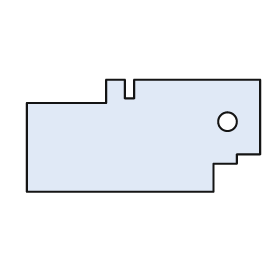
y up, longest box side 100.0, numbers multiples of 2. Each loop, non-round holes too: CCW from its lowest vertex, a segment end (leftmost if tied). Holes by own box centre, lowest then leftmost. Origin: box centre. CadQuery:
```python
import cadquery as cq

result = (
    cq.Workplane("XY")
    .moveTo(-50.0, -24.0)
    .lineTo(30.0, -24.0)
    .lineTo(30.0, -12.0)
    .lineTo(40.0, -12.0)
    .lineTo(40.0, -8.0)
    .lineTo(50.0, -8.0)
    .lineTo(50.0, 24.0)
    .lineTo(-4.0, 24.0)
    .lineTo(-4.0, 16.0)
    .lineTo(-8.0, 16.0)
    .lineTo(-8.0, 24.0)
    .lineTo(-16.0, 24.0)
    .lineTo(-16.0, 14.0)
    .lineTo(-50.0, 14.0)
    .close()
    .moveTo(36.0, 6.0)
    .circle(4.0)
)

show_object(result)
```